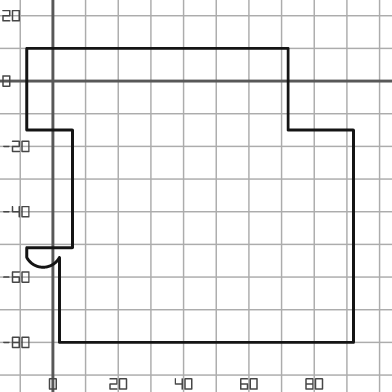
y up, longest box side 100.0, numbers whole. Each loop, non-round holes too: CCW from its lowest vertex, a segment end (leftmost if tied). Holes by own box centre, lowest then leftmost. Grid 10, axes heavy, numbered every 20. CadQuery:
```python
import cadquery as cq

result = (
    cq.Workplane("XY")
    .moveTo(2.0, -80.0)
    .lineTo(92.0, -80.0)
    .lineTo(92.0, -15.0)
    .lineTo(72.0, -15.0)
    .lineTo(72.0, 10.0)
    .lineTo(-8.0, 10.0)
    .lineTo(-8.0, -15.0)
    .lineTo(6.0, -15.0)
    .lineTo(6.0, -51.0)
    .lineTo(-8.0, -51.0)
    .lineTo(-8.0, -54.0)
    .threePointArc((-3.0, -57.0), (2.0, -54.0))
    .close()
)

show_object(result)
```